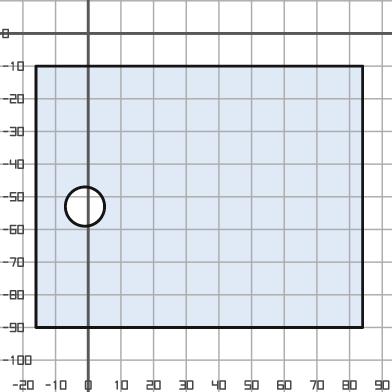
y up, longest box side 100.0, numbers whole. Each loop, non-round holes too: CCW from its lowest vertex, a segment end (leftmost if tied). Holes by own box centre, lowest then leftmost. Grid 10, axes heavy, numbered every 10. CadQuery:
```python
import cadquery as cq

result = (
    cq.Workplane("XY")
    .moveTo(-16.0, -90.0)
    .lineTo(84.0, -90.0)
    .lineTo(84.0, -10.0)
    .lineTo(-16.0, -10.0)
    .close()
    .moveTo(-1.0, -53.0)
    .circle(6.0)
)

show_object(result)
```